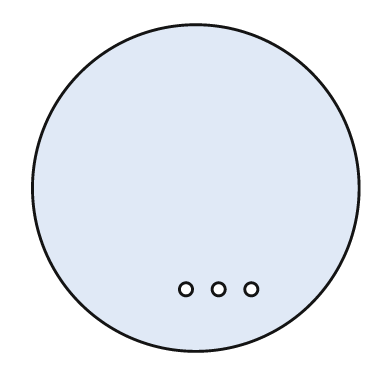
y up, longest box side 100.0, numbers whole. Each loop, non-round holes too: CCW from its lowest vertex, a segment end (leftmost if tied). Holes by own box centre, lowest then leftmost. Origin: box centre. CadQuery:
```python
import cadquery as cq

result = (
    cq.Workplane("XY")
    .moveTo(0.0, 0.0)
    .circle(50.0)
    .moveTo(-3.0, -31.0)
    .circle(2.0)
    .moveTo(7.0, -31.0)
    .circle(2.0)
    .moveTo(17.0, -31.0)
    .circle(2.0)
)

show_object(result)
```